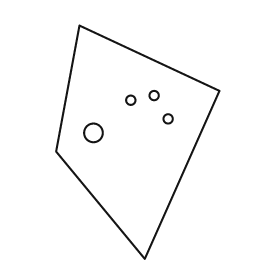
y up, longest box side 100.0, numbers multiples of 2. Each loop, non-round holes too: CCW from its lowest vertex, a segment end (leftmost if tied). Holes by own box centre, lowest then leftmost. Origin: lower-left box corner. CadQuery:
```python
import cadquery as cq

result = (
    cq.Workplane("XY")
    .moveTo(38.0, 0.0)
    .lineTo(70.0, 72.0)
    .lineTo(10.0, 100.0)
    .lineTo(0.0, 46.0)
    .close()
    .moveTo(16.0, 54.0)
    .circle(4.0)
    .moveTo(48.0, 60.0)
    .circle(2.0)
    .moveTo(32.0, 68.0)
    .circle(2.0)
    .moveTo(42.0, 70.0)
    .circle(2.0)
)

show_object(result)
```